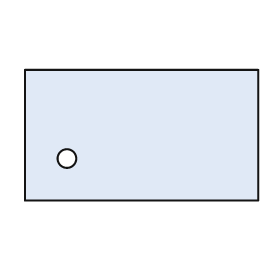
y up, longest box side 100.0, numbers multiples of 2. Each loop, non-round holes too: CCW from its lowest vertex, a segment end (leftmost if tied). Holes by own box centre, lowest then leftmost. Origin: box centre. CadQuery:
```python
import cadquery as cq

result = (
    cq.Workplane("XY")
    .moveTo(-50.0, -28.0)
    .lineTo(50.0, -28.0)
    .lineTo(50.0, 28.0)
    .lineTo(-50.0, 28.0)
    .close()
    .moveTo(-32.0, -10.0)
    .circle(4.0)
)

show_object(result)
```